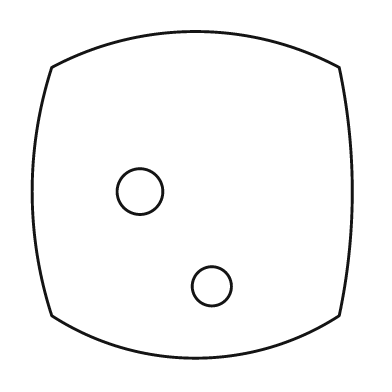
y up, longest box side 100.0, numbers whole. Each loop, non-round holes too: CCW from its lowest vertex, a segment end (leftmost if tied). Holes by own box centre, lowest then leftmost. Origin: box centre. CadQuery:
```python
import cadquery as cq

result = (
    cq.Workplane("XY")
    .moveTo(-43.0, -37.0)
    .threePointArc((1.0, -50.0), (45.0, -37.0))
    .threePointArc((49.0, 1.0), (45.0, 39.0))
    .threePointArc((1.0, 50.0), (-43.0, 39.0))
    .threePointArc((-49.0, 1.0), (-43.0, -37.0))
    .close()
    .moveTo(6.0, -28.0)
    .circle(6.0)
    .moveTo(-16.0, 1.0)
    .circle(7.0)
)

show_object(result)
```